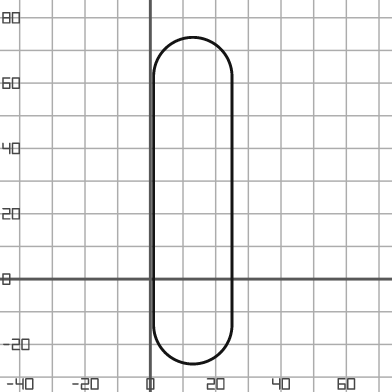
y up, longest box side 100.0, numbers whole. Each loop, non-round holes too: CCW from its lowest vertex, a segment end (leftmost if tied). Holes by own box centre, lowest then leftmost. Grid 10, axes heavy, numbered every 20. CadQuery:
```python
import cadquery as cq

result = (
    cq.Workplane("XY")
    .moveTo(1.0, -14.0)
    .threePointArc((13.0, -26.0), (25.0, -14.0))
    .lineTo(25.0, 62.0)
    .threePointArc((13.0, 74.0), (1.0, 62.0))
    .close()
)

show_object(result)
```